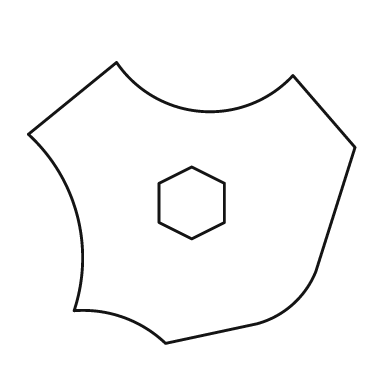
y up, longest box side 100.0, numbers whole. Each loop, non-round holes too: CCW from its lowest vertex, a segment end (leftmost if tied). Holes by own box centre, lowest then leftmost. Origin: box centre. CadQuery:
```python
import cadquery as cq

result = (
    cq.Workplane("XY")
    .moveTo(-8.0, -43.0)
    .lineTo(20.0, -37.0)
    .threePointArc((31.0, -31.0), (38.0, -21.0))
    .lineTo(50.0, 17.0)
    .lineTo(31.0, 39.0)
    .threePointArc((3.0, 28.0), (-23.0, 43.0))
    .lineTo(-50.0, 21.0)
    .threePointArc((-35.0, -4.0), (-36.0, -33.0))
    .threePointArc((-21.0, -35.0), (-8.0, -43.0))
    .close()
    .moveTo(0.0, -11.0)
    .lineTo(10.0, -6.0)
    .lineTo(10.0, 6.0)
    .lineTo(0.0, 11.0)
    .lineTo(-10.0, 6.0)
    .lineTo(-10.0, -6.0)
    .close()
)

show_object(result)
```